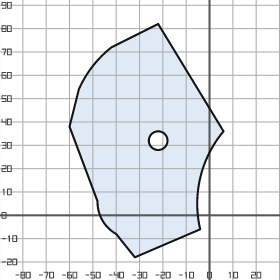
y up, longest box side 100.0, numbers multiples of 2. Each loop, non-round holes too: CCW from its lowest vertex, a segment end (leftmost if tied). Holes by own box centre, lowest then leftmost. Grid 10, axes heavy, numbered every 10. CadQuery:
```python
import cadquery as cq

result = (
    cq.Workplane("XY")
    .moveTo(-32.0, -18.0)
    .lineTo(-4.0, -6.0)
    .threePointArc((-4.0, 16.0), (6.0, 36.0))
    .lineTo(-22.0, 82.0)
    .lineTo(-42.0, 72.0)
    .threePointArc((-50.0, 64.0), (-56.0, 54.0))
    .lineTo(-60.0, 38.0)
    .lineTo(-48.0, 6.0)
    .threePointArc((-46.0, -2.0), (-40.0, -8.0))
    .close()
    .moveTo(-22.0, 32.0)
    .circle(4.0)
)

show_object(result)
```